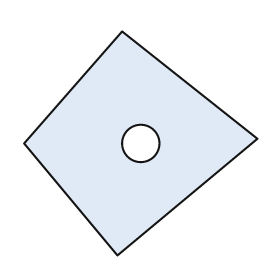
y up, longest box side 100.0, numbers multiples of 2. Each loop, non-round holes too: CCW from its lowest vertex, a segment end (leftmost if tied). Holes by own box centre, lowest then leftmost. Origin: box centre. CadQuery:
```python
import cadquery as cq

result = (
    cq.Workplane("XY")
    .moveTo(-10.0, -48.0)
    .lineTo(50.0, 2.0)
    .lineTo(-8.0, 48.0)
    .lineTo(-50.0, 0.0)
    .close()
    .moveTo(0.0, 0.0)
    .circle(8.0)
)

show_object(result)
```